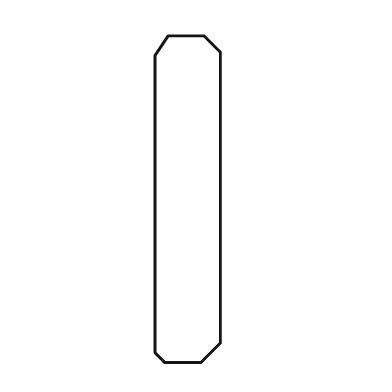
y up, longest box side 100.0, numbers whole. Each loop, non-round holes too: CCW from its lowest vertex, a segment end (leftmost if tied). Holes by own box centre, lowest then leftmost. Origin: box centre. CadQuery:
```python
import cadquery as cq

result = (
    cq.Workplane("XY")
    .moveTo(-7.0, -50.0)
    .lineTo(4.0, -50.0)
    .lineTo(10.0, -44.0)
    .lineTo(10.0, 45.0)
    .lineTo(5.0, 50.0)
    .lineTo(-6.0, 50.0)
    .lineTo(-10.0, 44.0)
    .lineTo(-10.0, -47.0)
    .close()
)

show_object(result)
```